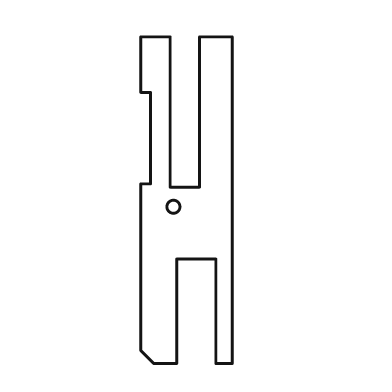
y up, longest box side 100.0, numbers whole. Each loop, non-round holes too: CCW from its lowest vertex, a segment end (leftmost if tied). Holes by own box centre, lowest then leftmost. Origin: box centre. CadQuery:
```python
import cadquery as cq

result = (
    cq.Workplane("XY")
    .moveTo(-10.0, -50.0)
    .lineTo(-3.0, -50.0)
    .lineTo(-3.0, -18.0)
    .lineTo(9.0, -18.0)
    .lineTo(9.0, -50.0)
    .lineTo(14.0, -50.0)
    .lineTo(14.0, 50.0)
    .lineTo(4.0, 50.0)
    .lineTo(4.0, 4.0)
    .lineTo(-5.0, 4.0)
    .lineTo(-5.0, 50.0)
    .lineTo(-14.0, 50.0)
    .lineTo(-14.0, 33.0)
    .lineTo(-11.0, 33.0)
    .lineTo(-11.0, 5.0)
    .lineTo(-14.0, 5.0)
    .lineTo(-14.0, -46.0)
    .close()
    .moveTo(-4.0, -2.0)
    .circle(2.0)
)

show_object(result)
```